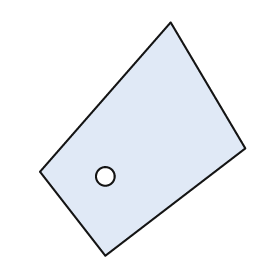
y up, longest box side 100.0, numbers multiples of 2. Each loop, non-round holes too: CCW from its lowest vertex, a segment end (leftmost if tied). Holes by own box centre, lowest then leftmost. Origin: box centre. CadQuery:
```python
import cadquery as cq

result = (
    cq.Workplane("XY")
    .moveTo(-16.0, -50.0)
    .lineTo(44.0, -4.0)
    .lineTo(12.0, 50.0)
    .lineTo(-44.0, -14.0)
    .close()
    .moveTo(-16.0, -16.0)
    .circle(4.0)
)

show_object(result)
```